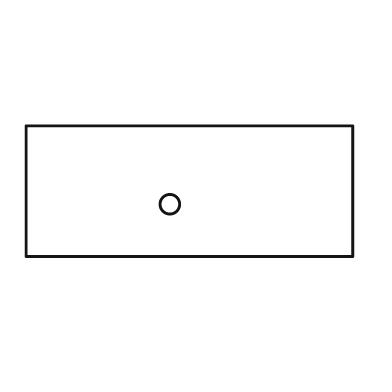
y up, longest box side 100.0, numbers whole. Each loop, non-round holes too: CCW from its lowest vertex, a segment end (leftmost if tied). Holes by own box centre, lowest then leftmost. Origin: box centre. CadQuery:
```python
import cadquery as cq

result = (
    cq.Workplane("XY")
    .moveTo(-50.0, -20.0)
    .lineTo(50.0, -20.0)
    .lineTo(50.0, 20.0)
    .lineTo(-50.0, 20.0)
    .close()
    .moveTo(-6.0, -4.0)
    .circle(3.0)
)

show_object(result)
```